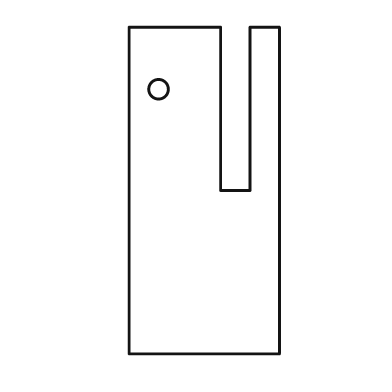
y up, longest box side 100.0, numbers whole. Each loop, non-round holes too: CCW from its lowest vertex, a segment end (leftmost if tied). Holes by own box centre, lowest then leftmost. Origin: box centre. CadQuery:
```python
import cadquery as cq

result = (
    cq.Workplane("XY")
    .moveTo(-23.0, -50.0)
    .lineTo(23.0, -50.0)
    .lineTo(23.0, 50.0)
    .lineTo(14.0, 50.0)
    .lineTo(14.0, 0.0)
    .lineTo(5.0, 0.0)
    .lineTo(5.0, 50.0)
    .lineTo(-23.0, 50.0)
    .close()
    .moveTo(-14.0, 31.0)
    .circle(3.0)
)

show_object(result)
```